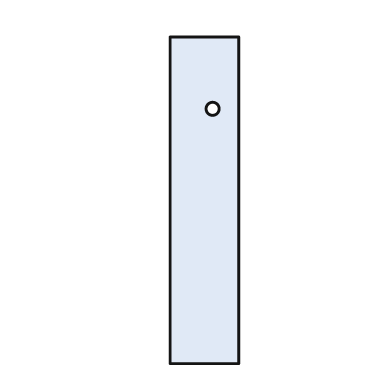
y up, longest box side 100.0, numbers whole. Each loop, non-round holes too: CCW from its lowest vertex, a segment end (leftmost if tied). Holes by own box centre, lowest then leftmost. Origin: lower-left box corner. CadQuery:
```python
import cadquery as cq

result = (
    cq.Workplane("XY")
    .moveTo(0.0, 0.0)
    .lineTo(21.0, 0.0)
    .lineTo(21.0, 100.0)
    .lineTo(0.0, 100.0)
    .close()
    .moveTo(13.0, 78.0)
    .circle(2.0)
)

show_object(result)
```